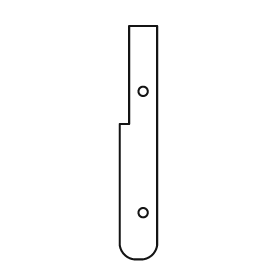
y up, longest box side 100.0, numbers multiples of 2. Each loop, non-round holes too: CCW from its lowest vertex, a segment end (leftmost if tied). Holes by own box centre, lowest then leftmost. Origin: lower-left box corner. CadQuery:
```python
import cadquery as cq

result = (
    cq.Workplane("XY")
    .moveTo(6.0, 0.0)
    .lineTo(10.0, 0.0)
    .threePointArc((14.0, 2.0), (16.0, 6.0))
    .lineTo(16.0, 100.0)
    .lineTo(4.0, 100.0)
    .lineTo(4.0, 58.0)
    .lineTo(0.0, 58.0)
    .lineTo(0.0, 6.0)
    .threePointArc((2.0, 2.0), (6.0, 0.0))
    .close()
    .moveTo(10.0, 20.0)
    .circle(2.0)
    .moveTo(10.0, 72.0)
    .circle(2.0)
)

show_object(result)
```